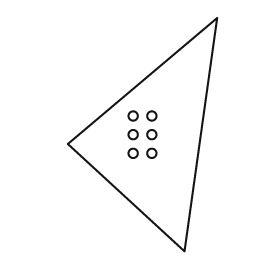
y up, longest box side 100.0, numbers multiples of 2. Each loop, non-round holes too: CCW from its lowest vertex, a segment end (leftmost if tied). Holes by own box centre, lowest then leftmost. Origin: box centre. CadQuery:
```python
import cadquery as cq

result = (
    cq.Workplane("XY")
    .moveTo(18.0, -50.0)
    .lineTo(32.0, 50.0)
    .lineTo(-32.0, -4.0)
    .close()
    .moveTo(-4.0, -8.0)
    .circle(2.0)
    .moveTo(4.0, -8.0)
    .circle(2.0)
    .moveTo(-4.0, 0.0)
    .circle(2.0)
    .moveTo(4.0, 0.0)
    .circle(2.0)
    .moveTo(-4.0, 8.0)
    .circle(2.0)
    .moveTo(4.0, 8.0)
    .circle(2.0)
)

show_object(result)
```